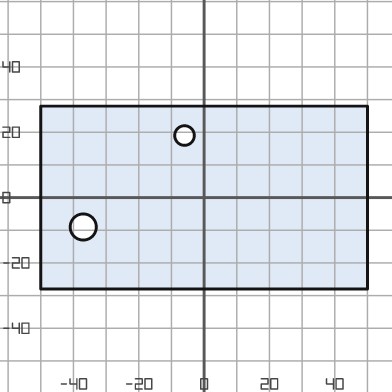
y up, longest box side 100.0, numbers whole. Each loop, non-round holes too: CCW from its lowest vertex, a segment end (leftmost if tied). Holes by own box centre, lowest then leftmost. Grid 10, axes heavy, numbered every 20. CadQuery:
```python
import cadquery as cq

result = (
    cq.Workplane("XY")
    .moveTo(-50.0, -28.0)
    .lineTo(50.0, -28.0)
    .lineTo(50.0, 28.0)
    .lineTo(-50.0, 28.0)
    .close()
    .moveTo(-37.0, -9.0)
    .circle(4.0)
    .moveTo(-6.0, 19.0)
    .circle(3.0)
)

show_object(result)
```